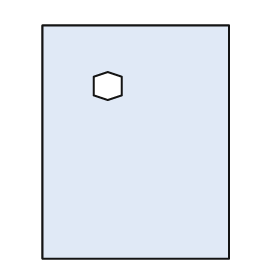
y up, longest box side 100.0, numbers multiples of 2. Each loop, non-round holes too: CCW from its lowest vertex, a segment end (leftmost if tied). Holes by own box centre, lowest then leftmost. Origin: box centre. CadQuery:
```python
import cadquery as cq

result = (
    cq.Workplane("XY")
    .moveTo(-40.0, -50.0)
    .lineTo(40.0, -50.0)
    .lineTo(40.0, 50.0)
    .lineTo(-40.0, 50.0)
    .close()
    .moveTo(-12.0, 18.0)
    .lineTo(-6.0, 20.0)
    .lineTo(-6.0, 28.0)
    .lineTo(-12.0, 30.0)
    .lineTo(-18.0, 28.0)
    .lineTo(-18.0, 20.0)
    .close()
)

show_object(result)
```